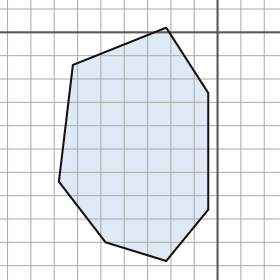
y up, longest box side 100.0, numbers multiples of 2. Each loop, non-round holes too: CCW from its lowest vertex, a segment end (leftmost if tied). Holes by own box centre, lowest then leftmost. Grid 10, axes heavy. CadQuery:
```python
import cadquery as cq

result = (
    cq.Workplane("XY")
    .moveTo(-22.0, -98.0)
    .lineTo(-4.0, -76.0)
    .lineTo(-4.0, -26.0)
    .lineTo(-22.0, 2.0)
    .lineTo(-62.0, -14.0)
    .lineTo(-68.0, -64.0)
    .lineTo(-48.0, -90.0)
    .close()
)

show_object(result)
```